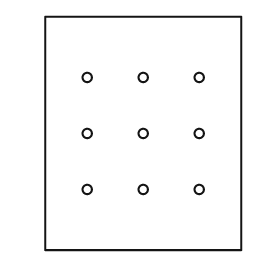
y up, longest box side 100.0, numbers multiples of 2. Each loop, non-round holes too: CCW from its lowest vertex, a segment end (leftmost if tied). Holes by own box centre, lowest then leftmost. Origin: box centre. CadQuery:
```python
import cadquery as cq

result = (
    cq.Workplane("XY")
    .moveTo(-42.0, -50.0)
    .lineTo(42.0, -50.0)
    .lineTo(42.0, 50.0)
    .lineTo(-42.0, 50.0)
    .close()
    .moveTo(-24.0, -24.0)
    .circle(2.0)
    .moveTo(0.0, -24.0)
    .circle(2.0)
    .moveTo(24.0, -24.0)
    .circle(2.0)
    .moveTo(-24.0, 0.0)
    .circle(2.0)
    .moveTo(0.0, 0.0)
    .circle(2.0)
    .moveTo(24.0, 0.0)
    .circle(2.0)
    .moveTo(-24.0, 24.0)
    .circle(2.0)
    .moveTo(0.0, 24.0)
    .circle(2.0)
    .moveTo(24.0, 24.0)
    .circle(2.0)
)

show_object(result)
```